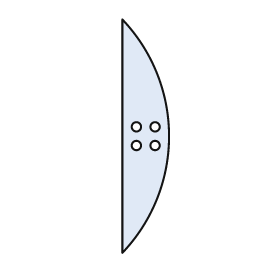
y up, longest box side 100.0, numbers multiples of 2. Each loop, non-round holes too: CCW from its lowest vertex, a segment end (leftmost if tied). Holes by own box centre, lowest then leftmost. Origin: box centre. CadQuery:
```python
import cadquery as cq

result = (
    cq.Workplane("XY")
    .moveTo(-10.0, -50.0)
    .threePointArc((10.0, 0.0), (-10.0, 50.0))
    .close()
    .moveTo(-4.0, -4.0)
    .circle(2.0)
    .moveTo(4.0, -4.0)
    .circle(2.0)
    .moveTo(-4.0, 4.0)
    .circle(2.0)
    .moveTo(4.0, 4.0)
    .circle(2.0)
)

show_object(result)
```